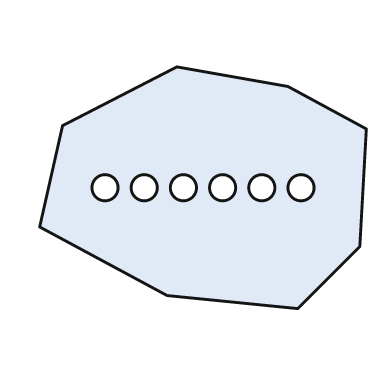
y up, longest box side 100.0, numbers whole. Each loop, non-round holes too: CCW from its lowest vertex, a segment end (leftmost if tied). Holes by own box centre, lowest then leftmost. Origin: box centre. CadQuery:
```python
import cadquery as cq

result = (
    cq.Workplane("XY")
    .moveTo(29.0, -37.0)
    .lineTo(48.0, -18.0)
    .lineTo(50.0, 18.0)
    .lineTo(26.0, 31.0)
    .lineTo(-8.0, 37.0)
    .lineTo(-43.0, 19.0)
    .lineTo(-50.0, -12.0)
    .lineTo(-11.0, -33.0)
    .close()
    .moveTo(-30.0, 0.0)
    .circle(4.0)
    .moveTo(-18.0, 0.0)
    .circle(4.0)
    .moveTo(-6.0, 0.0)
    .circle(4.0)
    .moveTo(6.0, 0.0)
    .circle(4.0)
    .moveTo(18.0, 0.0)
    .circle(4.0)
    .moveTo(30.0, 0.0)
    .circle(4.0)
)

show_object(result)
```